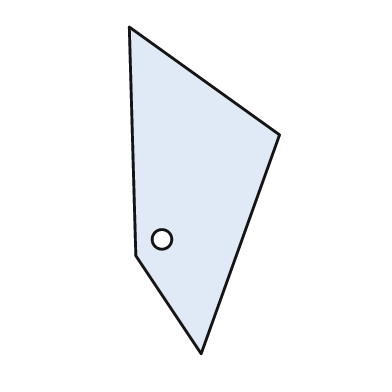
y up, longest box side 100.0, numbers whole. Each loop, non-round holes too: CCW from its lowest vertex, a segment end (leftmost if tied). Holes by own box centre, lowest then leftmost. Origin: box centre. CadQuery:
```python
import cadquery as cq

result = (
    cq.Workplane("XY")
    .moveTo(-1.0, -50.0)
    .lineTo(23.0, 17.0)
    .lineTo(-23.0, 50.0)
    .lineTo(-21.0, -20.0)
    .close()
    .moveTo(-13.0, -15.0)
    .circle(3.0)
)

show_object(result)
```